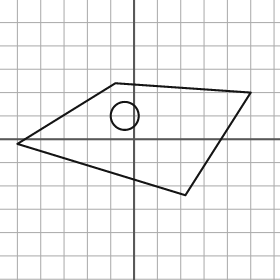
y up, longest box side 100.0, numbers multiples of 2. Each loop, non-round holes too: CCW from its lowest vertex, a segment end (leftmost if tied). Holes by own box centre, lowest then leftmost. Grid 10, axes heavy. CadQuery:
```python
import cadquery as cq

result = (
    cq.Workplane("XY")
    .moveTo(22.0, -24.0)
    .lineTo(50.0, 20.0)
    .lineTo(-8.0, 24.0)
    .lineTo(-50.0, -2.0)
    .close()
    .moveTo(-4.0, 10.0)
    .circle(6.0)
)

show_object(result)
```